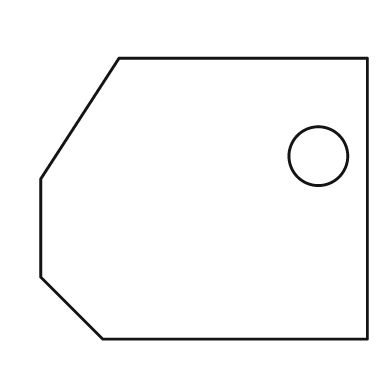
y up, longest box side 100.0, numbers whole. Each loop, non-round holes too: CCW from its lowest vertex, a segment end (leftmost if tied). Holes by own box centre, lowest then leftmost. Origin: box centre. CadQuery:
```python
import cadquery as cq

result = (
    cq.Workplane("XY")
    .moveTo(-31.0, -43.0)
    .lineTo(50.0, -43.0)
    .lineTo(50.0, 43.0)
    .lineTo(-26.0, 43.0)
    .lineTo(-50.0, 6.0)
    .lineTo(-50.0, -24.0)
    .close()
    .moveTo(35.0, 13.0)
    .circle(9.0)
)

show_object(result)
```